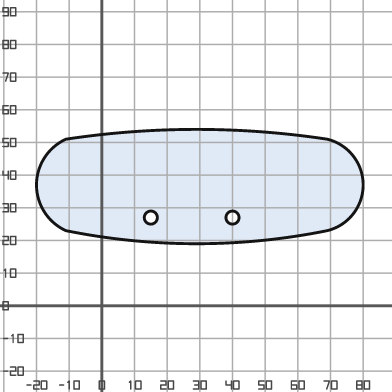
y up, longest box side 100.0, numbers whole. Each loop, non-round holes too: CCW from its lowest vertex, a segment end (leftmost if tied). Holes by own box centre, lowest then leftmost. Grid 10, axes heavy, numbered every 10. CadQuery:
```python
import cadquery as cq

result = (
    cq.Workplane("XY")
    .moveTo(-11.0, 23.0)
    .threePointArc((29.0, 19.0), (69.0, 23.0))
    .threePointArc((80.0, 37.0), (69.0, 51.0))
    .threePointArc((29.0, 54.0), (-11.0, 51.0))
    .threePointArc((-20.0, 37.0), (-11.0, 23.0))
    .close()
    .moveTo(15.0, 27.0)
    .circle(2.0)
    .moveTo(40.0, 27.0)
    .circle(2.0)
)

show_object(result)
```